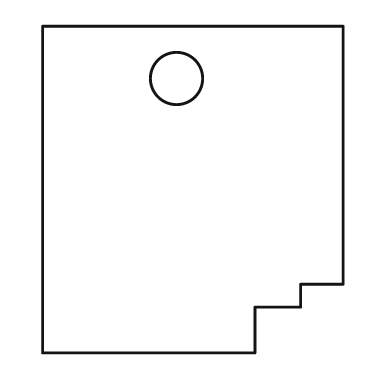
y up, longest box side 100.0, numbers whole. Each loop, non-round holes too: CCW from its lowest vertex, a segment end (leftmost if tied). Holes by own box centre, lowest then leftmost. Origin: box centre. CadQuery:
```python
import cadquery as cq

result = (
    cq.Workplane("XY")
    .moveTo(-46.0, -50.0)
    .lineTo(19.0, -50.0)
    .lineTo(19.0, -36.0)
    .lineTo(33.0, -36.0)
    .lineTo(33.0, -29.0)
    .lineTo(46.0, -29.0)
    .lineTo(46.0, 50.0)
    .lineTo(-46.0, 50.0)
    .close()
    .moveTo(-5.0, 34.0)
    .circle(8.0)
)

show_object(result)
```